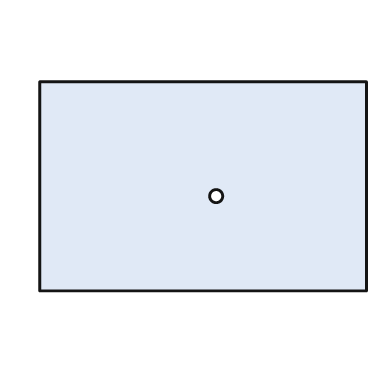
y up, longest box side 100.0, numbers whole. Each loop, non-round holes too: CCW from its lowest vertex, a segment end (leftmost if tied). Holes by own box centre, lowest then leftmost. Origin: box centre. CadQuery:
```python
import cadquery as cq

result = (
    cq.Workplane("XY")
    .moveTo(-50.0, -32.0)
    .lineTo(50.0, -32.0)
    .lineTo(50.0, 32.0)
    .lineTo(-50.0, 32.0)
    .close()
    .moveTo(4.0, -3.0)
    .circle(2.0)
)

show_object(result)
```